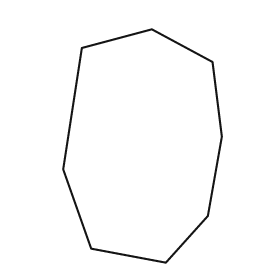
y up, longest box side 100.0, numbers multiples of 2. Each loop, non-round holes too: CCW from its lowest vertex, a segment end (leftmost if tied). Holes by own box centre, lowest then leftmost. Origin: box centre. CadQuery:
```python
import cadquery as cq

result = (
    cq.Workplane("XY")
    .moveTo(10.0, -50.0)
    .lineTo(28.0, -30.0)
    .lineTo(34.0, 4.0)
    .lineTo(30.0, 36.0)
    .lineTo(4.0, 50.0)
    .lineTo(-26.0, 42.0)
    .lineTo(-34.0, -10.0)
    .lineTo(-22.0, -44.0)
    .close()
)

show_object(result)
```